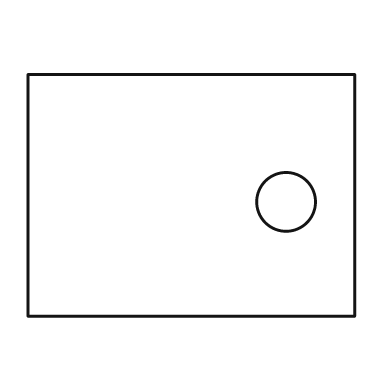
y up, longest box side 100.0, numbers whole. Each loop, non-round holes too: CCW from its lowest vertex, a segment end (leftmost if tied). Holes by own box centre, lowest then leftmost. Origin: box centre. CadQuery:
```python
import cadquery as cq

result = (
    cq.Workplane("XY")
    .moveTo(-50.0, -37.0)
    .lineTo(50.0, -37.0)
    .lineTo(50.0, 37.0)
    .lineTo(-50.0, 37.0)
    .close()
    .moveTo(29.0, -2.0)
    .circle(9.0)
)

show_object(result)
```